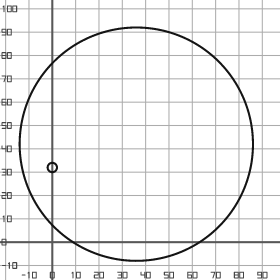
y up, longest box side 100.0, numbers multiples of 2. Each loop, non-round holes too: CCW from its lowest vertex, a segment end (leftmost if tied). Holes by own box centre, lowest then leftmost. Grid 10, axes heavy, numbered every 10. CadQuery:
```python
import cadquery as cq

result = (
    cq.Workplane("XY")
    .moveTo(36.0, 42.0)
    .circle(50.0)
    .moveTo(0.0, 32.0)
    .circle(2.0)
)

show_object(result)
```